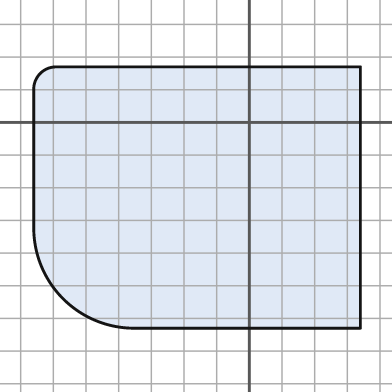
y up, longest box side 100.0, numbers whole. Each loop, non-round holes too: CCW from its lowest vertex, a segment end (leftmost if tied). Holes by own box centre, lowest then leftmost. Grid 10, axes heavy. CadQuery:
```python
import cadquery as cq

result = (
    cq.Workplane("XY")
    .moveTo(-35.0, -63.0)
    .lineTo(34.0, -63.0)
    .lineTo(34.0, 17.0)
    .lineTo(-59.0, 17.0)
    .threePointArc((-64.0, 15.0), (-66.0, 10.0))
    .lineTo(-66.0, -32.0)
    .threePointArc((-57.0, -54.0), (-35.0, -63.0))
    .close()
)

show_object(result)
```